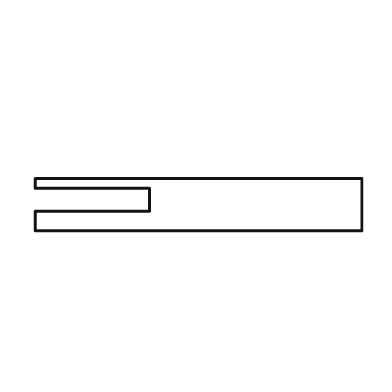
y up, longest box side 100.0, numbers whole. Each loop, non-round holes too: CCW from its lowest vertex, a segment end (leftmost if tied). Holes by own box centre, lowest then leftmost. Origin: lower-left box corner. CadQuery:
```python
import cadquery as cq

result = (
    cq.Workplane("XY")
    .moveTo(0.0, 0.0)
    .lineTo(100.0, 0.0)
    .lineTo(100.0, 16.0)
    .lineTo(0.0, 16.0)
    .lineTo(0.0, 13.0)
    .lineTo(35.0, 13.0)
    .lineTo(35.0, 6.0)
    .lineTo(0.0, 6.0)
    .close()
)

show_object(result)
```